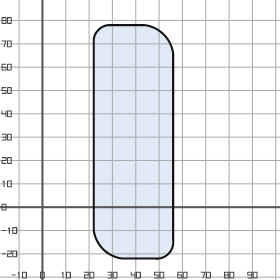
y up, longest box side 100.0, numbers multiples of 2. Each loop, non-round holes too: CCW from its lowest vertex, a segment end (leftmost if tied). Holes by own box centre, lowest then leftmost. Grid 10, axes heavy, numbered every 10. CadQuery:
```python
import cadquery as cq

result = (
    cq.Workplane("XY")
    .moveTo(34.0, -22.0)
    .lineTo(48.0, -22.0)
    .threePointArc((54.0, -20.0), (56.0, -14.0))
    .lineTo(56.0, 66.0)
    .threePointArc((52.0, 74.0), (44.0, 78.0))
    .lineTo(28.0, 78.0)
    .threePointArc((24.0, 76.0), (22.0, 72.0))
    .lineTo(22.0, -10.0)
    .threePointArc((26.0, -18.0), (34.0, -22.0))
    .close()
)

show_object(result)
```